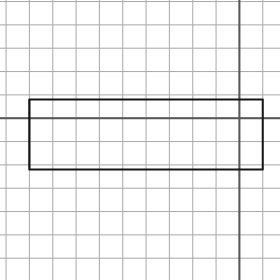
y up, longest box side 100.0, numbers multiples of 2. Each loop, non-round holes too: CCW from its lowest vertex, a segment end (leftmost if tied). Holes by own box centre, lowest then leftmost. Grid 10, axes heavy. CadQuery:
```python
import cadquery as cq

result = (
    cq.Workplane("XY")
    .moveTo(-90.0, -22.0)
    .lineTo(10.0, -22.0)
    .lineTo(10.0, 8.0)
    .lineTo(-90.0, 8.0)
    .close()
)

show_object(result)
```